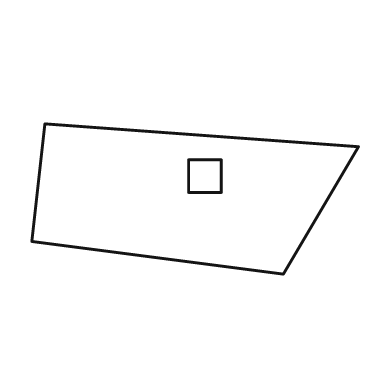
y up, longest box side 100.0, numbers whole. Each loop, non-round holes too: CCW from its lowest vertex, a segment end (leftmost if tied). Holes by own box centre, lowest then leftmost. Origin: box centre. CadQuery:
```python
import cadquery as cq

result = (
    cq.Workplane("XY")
    .moveTo(27.0, -23.0)
    .lineTo(50.0, 16.0)
    .lineTo(-46.0, 23.0)
    .lineTo(-50.0, -13.0)
    .close()
    .moveTo(-2.0, 2.0)
    .lineTo(8.0, 2.0)
    .lineTo(8.0, 12.0)
    .lineTo(-2.0, 12.0)
    .close()
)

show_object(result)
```